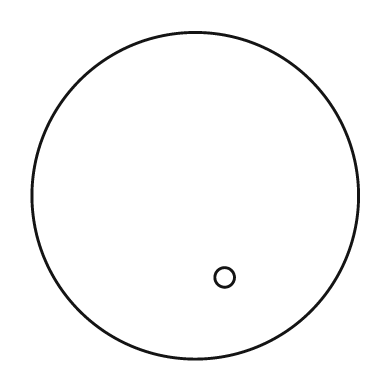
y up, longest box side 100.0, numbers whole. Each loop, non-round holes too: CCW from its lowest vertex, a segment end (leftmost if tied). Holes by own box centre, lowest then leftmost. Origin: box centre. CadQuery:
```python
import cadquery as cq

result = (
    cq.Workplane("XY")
    .moveTo(0.0, 0.0)
    .circle(50.0)
    .moveTo(9.0, -25.0)
    .circle(3.0)
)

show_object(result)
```